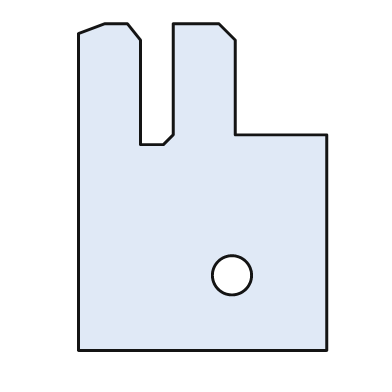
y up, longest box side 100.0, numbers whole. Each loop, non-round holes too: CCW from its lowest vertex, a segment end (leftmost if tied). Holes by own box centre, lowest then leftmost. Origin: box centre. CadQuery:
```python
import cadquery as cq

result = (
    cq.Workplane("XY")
    .moveTo(-38.0, -50.0)
    .lineTo(38.0, -50.0)
    .lineTo(38.0, 16.0)
    .lineTo(10.0, 16.0)
    .lineTo(10.0, 45.0)
    .lineTo(5.0, 50.0)
    .lineTo(-9.0, 50.0)
    .lineTo(-9.0, 16.0)
    .lineTo(-12.0, 13.0)
    .lineTo(-19.0, 13.0)
    .lineTo(-19.0, 45.0)
    .lineTo(-23.0, 50.0)
    .lineTo(-30.0, 50.0)
    .lineTo(-38.0, 47.0)
    .close()
    .moveTo(9.0, -27.0)
    .circle(6.0)
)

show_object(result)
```